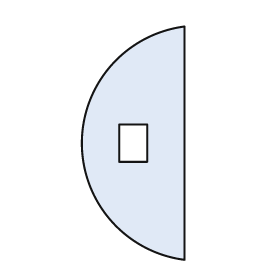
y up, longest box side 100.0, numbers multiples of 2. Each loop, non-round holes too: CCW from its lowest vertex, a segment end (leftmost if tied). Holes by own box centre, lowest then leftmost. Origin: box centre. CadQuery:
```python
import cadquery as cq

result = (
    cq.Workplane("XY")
    .moveTo(22.0, -50.0)
    .lineTo(22.0, 50.0)
    .threePointArc((-22.0, 0.0), (22.0, -50.0))
    .close()
    .moveTo(-6.0, -8.0)
    .lineTo(6.0, -8.0)
    .lineTo(6.0, 8.0)
    .lineTo(-6.0, 8.0)
    .close()
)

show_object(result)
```